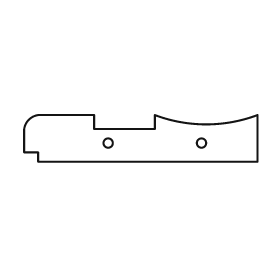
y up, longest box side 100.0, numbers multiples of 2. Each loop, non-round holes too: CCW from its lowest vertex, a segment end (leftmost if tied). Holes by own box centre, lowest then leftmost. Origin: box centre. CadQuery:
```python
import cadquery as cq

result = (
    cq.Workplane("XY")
    .moveTo(-44.0, -10.0)
    .lineTo(50.0, -10.0)
    .lineTo(50.0, 10.0)
    .threePointArc((28.0, 6.0), (6.0, 10.0))
    .lineTo(6.0, 4.0)
    .lineTo(-20.0, 4.0)
    .lineTo(-20.0, 10.0)
    .lineTo(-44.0, 10.0)
    .threePointArc((-48.0, 8.0), (-50.0, 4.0))
    .lineTo(-50.0, -6.0)
    .lineTo(-44.0, -6.0)
    .close()
    .moveTo(-14.0, -2.0)
    .circle(2.0)
    .moveTo(26.0, -2.0)
    .circle(2.0)
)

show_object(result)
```